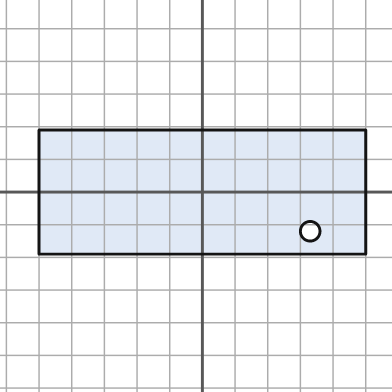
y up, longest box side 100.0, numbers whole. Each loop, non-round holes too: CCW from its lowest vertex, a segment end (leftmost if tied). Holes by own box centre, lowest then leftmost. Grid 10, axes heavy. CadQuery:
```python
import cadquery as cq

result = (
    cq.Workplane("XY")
    .moveTo(-50.0, -19.0)
    .lineTo(50.0, -19.0)
    .lineTo(50.0, 19.0)
    .lineTo(-50.0, 19.0)
    .close()
    .moveTo(33.0, -12.0)
    .circle(3.0)
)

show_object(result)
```